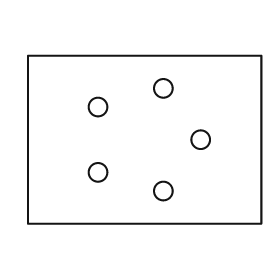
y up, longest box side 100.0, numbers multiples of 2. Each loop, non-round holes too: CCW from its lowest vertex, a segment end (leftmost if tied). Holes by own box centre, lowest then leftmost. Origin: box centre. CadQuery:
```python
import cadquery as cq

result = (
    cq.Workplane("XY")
    .moveTo(-50.0, -36.0)
    .lineTo(50.0, -36.0)
    .lineTo(50.0, 36.0)
    .lineTo(-50.0, 36.0)
    .close()
    .moveTo(8.0, -22.0)
    .circle(4.0)
    .moveTo(-20.0, -14.0)
    .circle(4.0)
    .moveTo(24.0, 0.0)
    .circle(4.0)
    .moveTo(-20.0, 14.0)
    .circle(4.0)
    .moveTo(8.0, 22.0)
    .circle(4.0)
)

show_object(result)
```